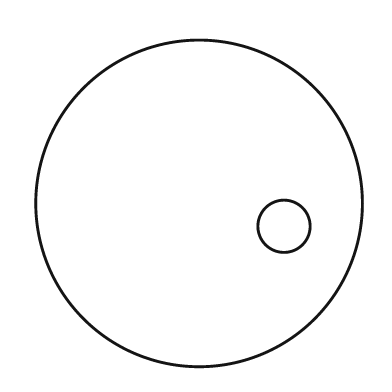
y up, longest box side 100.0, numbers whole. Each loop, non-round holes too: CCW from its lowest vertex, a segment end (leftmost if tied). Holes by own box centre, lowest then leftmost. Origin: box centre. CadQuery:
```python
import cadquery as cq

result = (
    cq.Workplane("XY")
    .moveTo(0.0, 0.0)
    .circle(50.0)
    .moveTo(26.0, -7.0)
    .circle(8.0)
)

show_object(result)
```